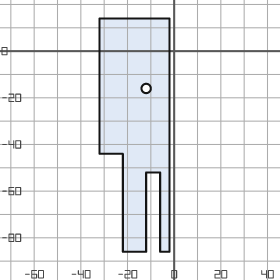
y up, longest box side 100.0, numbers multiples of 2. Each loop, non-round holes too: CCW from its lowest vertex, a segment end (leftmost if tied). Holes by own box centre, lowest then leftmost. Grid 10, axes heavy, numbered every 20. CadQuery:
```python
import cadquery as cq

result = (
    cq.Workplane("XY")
    .moveTo(-22.0, -86.0)
    .lineTo(-12.0, -86.0)
    .lineTo(-12.0, -52.0)
    .lineTo(-6.0, -52.0)
    .lineTo(-6.0, -86.0)
    .lineTo(-2.0, -86.0)
    .lineTo(-2.0, 14.0)
    .lineTo(-32.0, 14.0)
    .lineTo(-32.0, -44.0)
    .lineTo(-22.0, -44.0)
    .close()
    .moveTo(-12.0, -16.0)
    .circle(2.0)
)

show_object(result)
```